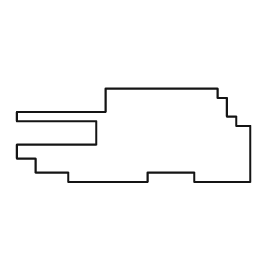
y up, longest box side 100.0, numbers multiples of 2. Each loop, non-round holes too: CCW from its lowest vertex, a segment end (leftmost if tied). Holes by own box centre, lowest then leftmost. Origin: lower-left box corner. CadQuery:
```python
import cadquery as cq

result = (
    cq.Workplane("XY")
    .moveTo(22.0, 0.0)
    .lineTo(56.0, 0.0)
    .lineTo(56.0, 4.0)
    .lineTo(76.0, 4.0)
    .lineTo(76.0, 0.0)
    .lineTo(100.0, 0.0)
    .lineTo(100.0, 24.0)
    .lineTo(94.0, 24.0)
    .lineTo(94.0, 28.0)
    .lineTo(90.0, 28.0)
    .lineTo(90.0, 36.0)
    .lineTo(86.0, 36.0)
    .lineTo(86.0, 40.0)
    .lineTo(38.0, 40.0)
    .lineTo(38.0, 30.0)
    .lineTo(0.0, 30.0)
    .lineTo(0.0, 26.0)
    .lineTo(34.0, 26.0)
    .lineTo(34.0, 16.0)
    .lineTo(0.0, 16.0)
    .lineTo(0.0, 10.0)
    .lineTo(8.0, 10.0)
    .lineTo(8.0, 4.0)
    .lineTo(22.0, 4.0)
    .close()
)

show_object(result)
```